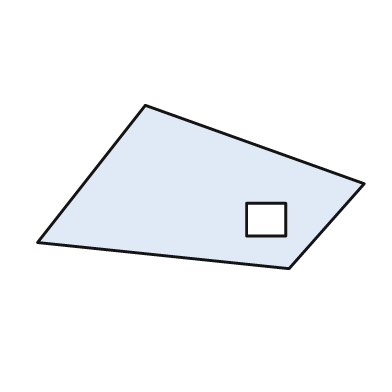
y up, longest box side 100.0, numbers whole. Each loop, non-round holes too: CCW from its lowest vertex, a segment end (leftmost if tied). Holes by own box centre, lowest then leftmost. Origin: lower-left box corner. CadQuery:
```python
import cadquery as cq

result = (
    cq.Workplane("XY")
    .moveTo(77.0, 0.0)
    .lineTo(100.0, 26.0)
    .lineTo(33.0, 50.0)
    .lineTo(0.0, 8.0)
    .close()
    .moveTo(64.0, 10.0)
    .lineTo(76.0, 10.0)
    .lineTo(76.0, 20.0)
    .lineTo(64.0, 20.0)
    .close()
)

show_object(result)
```